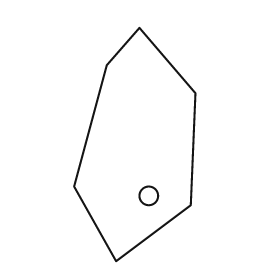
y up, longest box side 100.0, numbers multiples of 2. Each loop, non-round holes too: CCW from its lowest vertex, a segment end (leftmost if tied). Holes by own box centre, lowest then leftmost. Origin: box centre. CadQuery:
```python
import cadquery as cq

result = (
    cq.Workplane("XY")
    .moveTo(-8.0, -50.0)
    .lineTo(24.0, -26.0)
    .lineTo(26.0, 22.0)
    .lineTo(2.0, 50.0)
    .lineTo(-12.0, 34.0)
    .lineTo(-26.0, -18.0)
    .close()
    .moveTo(6.0, -22.0)
    .circle(4.0)
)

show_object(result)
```